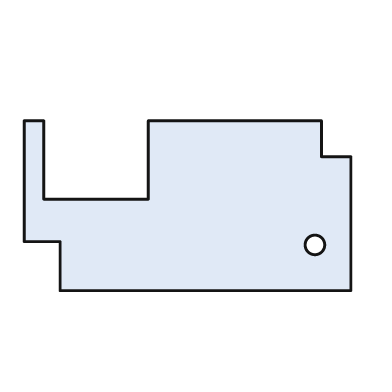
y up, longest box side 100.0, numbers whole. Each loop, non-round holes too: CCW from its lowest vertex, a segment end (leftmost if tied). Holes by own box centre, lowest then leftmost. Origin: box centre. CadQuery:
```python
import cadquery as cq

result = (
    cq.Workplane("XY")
    .moveTo(-39.0, -26.0)
    .lineTo(50.0, -26.0)
    .lineTo(50.0, 15.0)
    .lineTo(41.0, 15.0)
    .lineTo(41.0, 26.0)
    .lineTo(-12.0, 26.0)
    .lineTo(-12.0, 2.0)
    .lineTo(-44.0, 2.0)
    .lineTo(-44.0, 26.0)
    .lineTo(-50.0, 26.0)
    .lineTo(-50.0, -11.0)
    .lineTo(-39.0, -11.0)
    .close()
    .moveTo(39.0, -12.0)
    .circle(3.0)
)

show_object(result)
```